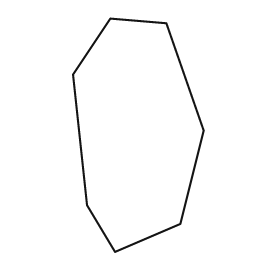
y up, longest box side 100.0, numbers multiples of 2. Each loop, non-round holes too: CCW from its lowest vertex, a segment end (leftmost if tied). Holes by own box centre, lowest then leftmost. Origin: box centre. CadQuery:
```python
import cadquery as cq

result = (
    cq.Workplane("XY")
    .moveTo(-10.0, -50.0)
    .lineTo(18.0, -38.0)
    .lineTo(28.0, 2.0)
    .lineTo(12.0, 48.0)
    .lineTo(-12.0, 50.0)
    .lineTo(-28.0, 26.0)
    .lineTo(-22.0, -30.0)
    .close()
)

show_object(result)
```